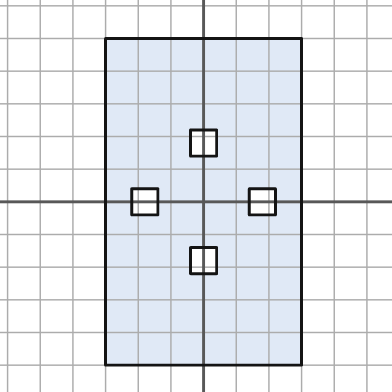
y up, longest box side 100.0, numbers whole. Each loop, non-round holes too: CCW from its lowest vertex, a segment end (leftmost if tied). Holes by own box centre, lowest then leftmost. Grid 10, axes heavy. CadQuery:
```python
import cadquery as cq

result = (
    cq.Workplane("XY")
    .moveTo(-30.0, -50.0)
    .lineTo(30.0, -50.0)
    .lineTo(30.0, 50.0)
    .lineTo(-30.0, 50.0)
    .close()
    .moveTo(-4.0, -22.0)
    .lineTo(4.0, -22.0)
    .lineTo(4.0, -14.0)
    .lineTo(-4.0, -14.0)
    .close()
    .moveTo(-22.0, -4.0)
    .lineTo(-14.0, -4.0)
    .lineTo(-14.0, 4.0)
    .lineTo(-22.0, 4.0)
    .close()
    .moveTo(14.0, -4.0)
    .lineTo(22.0, -4.0)
    .lineTo(22.0, 4.0)
    .lineTo(14.0, 4.0)
    .close()
    .moveTo(-4.0, 14.0)
    .lineTo(4.0, 14.0)
    .lineTo(4.0, 22.0)
    .lineTo(-4.0, 22.0)
    .close()
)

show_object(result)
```